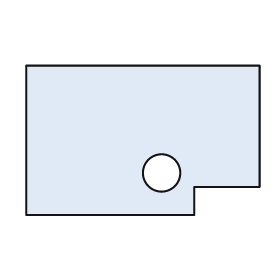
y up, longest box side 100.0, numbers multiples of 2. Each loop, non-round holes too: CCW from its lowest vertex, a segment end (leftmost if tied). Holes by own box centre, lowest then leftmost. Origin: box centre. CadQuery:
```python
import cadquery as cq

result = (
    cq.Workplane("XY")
    .moveTo(-50.0, -32.0)
    .lineTo(22.0, -32.0)
    .lineTo(22.0, -20.0)
    .lineTo(50.0, -20.0)
    .lineTo(50.0, 32.0)
    .lineTo(-50.0, 32.0)
    .close()
    .moveTo(8.0, -14.0)
    .circle(8.0)
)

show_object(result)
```